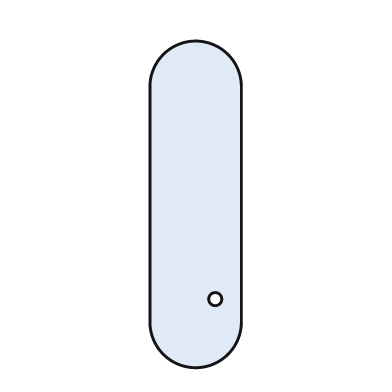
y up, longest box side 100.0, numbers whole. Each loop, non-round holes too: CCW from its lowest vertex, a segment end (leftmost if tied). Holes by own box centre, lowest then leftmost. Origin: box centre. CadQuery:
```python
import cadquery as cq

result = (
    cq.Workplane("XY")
    .moveTo(-14.0, -36.0)
    .threePointArc((0.0, -50.0), (14.0, -36.0))
    .lineTo(14.0, 36.0)
    .threePointArc((0.0, 50.0), (-14.0, 36.0))
    .close()
    .moveTo(6.0, -29.0)
    .circle(2.0)
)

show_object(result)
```